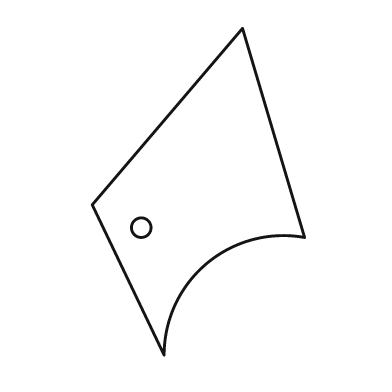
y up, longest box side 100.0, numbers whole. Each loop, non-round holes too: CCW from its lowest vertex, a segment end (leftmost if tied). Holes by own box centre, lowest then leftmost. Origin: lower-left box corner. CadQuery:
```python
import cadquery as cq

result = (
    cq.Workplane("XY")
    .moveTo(22.0, 0.0)
    .threePointArc((35.0, 28.0), (65.0, 36.0))
    .lineTo(46.0, 100.0)
    .lineTo(0.0, 46.0)
    .close()
    .moveTo(15.0, 39.0)
    .circle(3.0)
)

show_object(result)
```